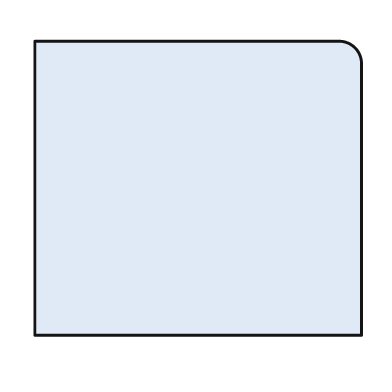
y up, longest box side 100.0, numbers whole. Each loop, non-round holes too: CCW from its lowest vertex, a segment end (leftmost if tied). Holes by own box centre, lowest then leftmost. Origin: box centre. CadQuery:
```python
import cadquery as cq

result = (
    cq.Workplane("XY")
    .moveTo(-50.0, -45.0)
    .lineTo(50.0, -45.0)
    .lineTo(50.0, 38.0)
    .threePointArc((48.0, 43.0), (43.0, 45.0))
    .lineTo(-50.0, 45.0)
    .close()
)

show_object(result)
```